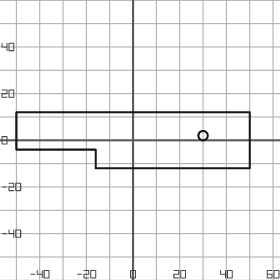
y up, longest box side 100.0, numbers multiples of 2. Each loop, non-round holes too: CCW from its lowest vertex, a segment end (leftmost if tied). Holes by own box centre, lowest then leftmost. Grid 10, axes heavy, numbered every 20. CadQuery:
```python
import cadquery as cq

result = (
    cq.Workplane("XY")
    .moveTo(-16.0, -12.0)
    .lineTo(50.0, -12.0)
    .lineTo(50.0, 12.0)
    .lineTo(-50.0, 12.0)
    .lineTo(-50.0, -4.0)
    .lineTo(-16.0, -4.0)
    .close()
    .moveTo(30.0, 2.0)
    .circle(2.0)
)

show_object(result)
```